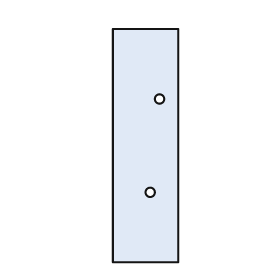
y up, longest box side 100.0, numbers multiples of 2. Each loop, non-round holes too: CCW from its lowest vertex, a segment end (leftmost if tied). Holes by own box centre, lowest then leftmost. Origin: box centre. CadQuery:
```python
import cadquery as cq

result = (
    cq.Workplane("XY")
    .moveTo(-14.0, -50.0)
    .lineTo(14.0, -50.0)
    .lineTo(14.0, 50.0)
    .lineTo(-14.0, 50.0)
    .close()
    .moveTo(2.0, -20.0)
    .circle(2.0)
    .moveTo(6.0, 20.0)
    .circle(2.0)
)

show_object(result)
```